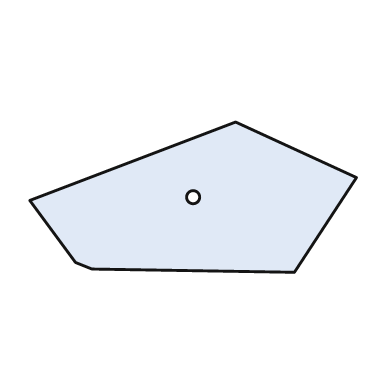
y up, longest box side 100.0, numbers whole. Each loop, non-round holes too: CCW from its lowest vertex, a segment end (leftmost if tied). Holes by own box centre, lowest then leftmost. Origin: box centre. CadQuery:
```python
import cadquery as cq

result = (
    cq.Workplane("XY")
    .moveTo(31.0, -23.0)
    .lineTo(50.0, 6.0)
    .lineTo(13.0, 23.0)
    .lineTo(-50.0, -1.0)
    .lineTo(-36.0, -20.0)
    .lineTo(-31.0, -22.0)
    .close()
    .moveTo(0.0, 0.0)
    .circle(2.0)
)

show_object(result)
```